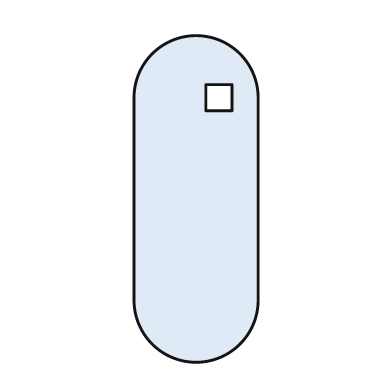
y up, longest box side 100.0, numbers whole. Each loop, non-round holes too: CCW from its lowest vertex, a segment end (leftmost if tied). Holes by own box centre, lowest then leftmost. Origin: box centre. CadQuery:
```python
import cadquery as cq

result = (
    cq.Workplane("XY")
    .moveTo(-19.0, -31.0)
    .threePointArc((0.0, -50.0), (19.0, -31.0))
    .lineTo(19.0, 31.0)
    .threePointArc((0.0, 50.0), (-19.0, 31.0))
    .close()
    .moveTo(3.0, 27.0)
    .lineTo(11.0, 27.0)
    .lineTo(11.0, 35.0)
    .lineTo(3.0, 35.0)
    .close()
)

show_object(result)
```